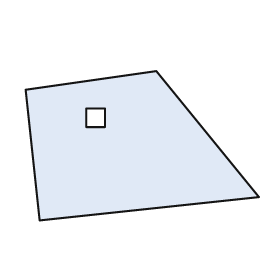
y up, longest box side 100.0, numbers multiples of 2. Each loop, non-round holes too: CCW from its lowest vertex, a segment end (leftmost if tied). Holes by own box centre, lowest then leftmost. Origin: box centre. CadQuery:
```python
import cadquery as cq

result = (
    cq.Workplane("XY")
    .moveTo(-44.0, -32.0)
    .lineTo(50.0, -22.0)
    .lineTo(6.0, 32.0)
    .lineTo(-50.0, 24.0)
    .close()
    .moveTo(-24.0, 8.0)
    .lineTo(-16.0, 8.0)
    .lineTo(-16.0, 16.0)
    .lineTo(-24.0, 16.0)
    .close()
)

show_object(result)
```